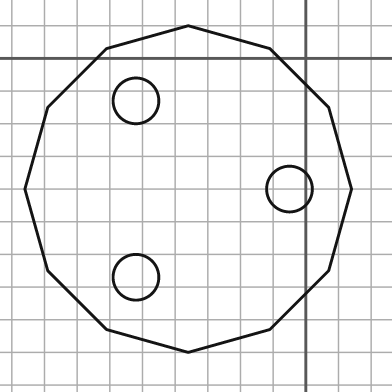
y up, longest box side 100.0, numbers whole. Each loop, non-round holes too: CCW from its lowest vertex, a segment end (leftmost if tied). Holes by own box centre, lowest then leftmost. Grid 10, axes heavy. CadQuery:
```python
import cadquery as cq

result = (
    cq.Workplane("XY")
    .moveTo(-36.0, -90.0)
    .lineTo(-11.0, -83.0)
    .lineTo(7.0, -65.0)
    .lineTo(14.0, -40.0)
    .lineTo(7.0, -15.0)
    .lineTo(-11.0, 3.0)
    .lineTo(-36.0, 10.0)
    .lineTo(-61.0, 3.0)
    .lineTo(-79.0, -15.0)
    .lineTo(-86.0, -40.0)
    .lineTo(-79.0, -65.0)
    .lineTo(-61.0, -83.0)
    .close()
    .moveTo(-52.0, -67.0)
    .circle(7.0)
    .moveTo(-5.0, -40.0)
    .circle(7.0)
    .moveTo(-52.0, -13.0)
    .circle(7.0)
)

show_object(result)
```